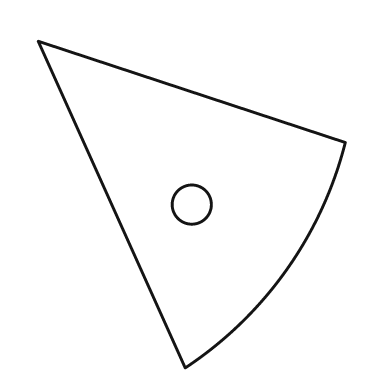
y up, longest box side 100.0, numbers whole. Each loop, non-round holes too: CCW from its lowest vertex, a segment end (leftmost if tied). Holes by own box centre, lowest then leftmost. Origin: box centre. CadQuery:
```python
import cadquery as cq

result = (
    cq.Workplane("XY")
    .moveTo(-2.0, -50.0)
    .threePointArc((29.0, -20.0), (47.0, 19.0))
    .lineTo(-47.0, 50.0)
    .close()
    .moveTo(0.0, 0.0)
    .circle(6.0)
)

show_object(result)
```